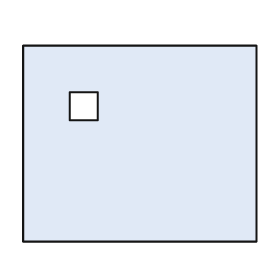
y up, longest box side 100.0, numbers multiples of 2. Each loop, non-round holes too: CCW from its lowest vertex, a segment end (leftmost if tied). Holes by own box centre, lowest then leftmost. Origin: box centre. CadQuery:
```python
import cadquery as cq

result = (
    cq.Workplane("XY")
    .moveTo(-50.0, -42.0)
    .lineTo(50.0, -42.0)
    .lineTo(50.0, 42.0)
    .lineTo(-50.0, 42.0)
    .close()
    .moveTo(-30.0, 10.0)
    .lineTo(-18.0, 10.0)
    .lineTo(-18.0, 22.0)
    .lineTo(-30.0, 22.0)
    .close()
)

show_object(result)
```